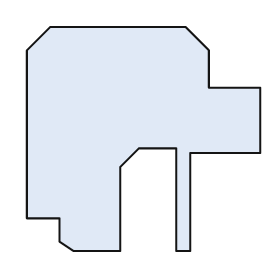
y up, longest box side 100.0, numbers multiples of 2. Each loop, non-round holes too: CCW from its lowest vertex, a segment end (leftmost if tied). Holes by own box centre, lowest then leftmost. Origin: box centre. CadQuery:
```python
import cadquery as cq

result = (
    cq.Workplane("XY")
    .moveTo(-30.0, -48.0)
    .lineTo(-10.0, -48.0)
    .lineTo(-10.0, -12.0)
    .lineTo(-2.0, -4.0)
    .lineTo(14.0, -4.0)
    .lineTo(14.0, -48.0)
    .lineTo(20.0, -48.0)
    .lineTo(20.0, -6.0)
    .lineTo(50.0, -6.0)
    .lineTo(50.0, 22.0)
    .lineTo(28.0, 22.0)
    .lineTo(28.0, 38.0)
    .lineTo(18.0, 48.0)
    .lineTo(-40.0, 48.0)
    .lineTo(-50.0, 38.0)
    .lineTo(-50.0, -34.0)
    .lineTo(-36.0, -34.0)
    .lineTo(-36.0, -44.0)
    .close()
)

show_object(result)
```